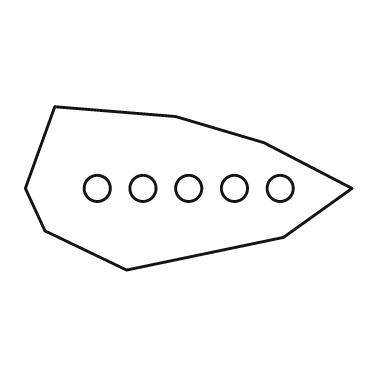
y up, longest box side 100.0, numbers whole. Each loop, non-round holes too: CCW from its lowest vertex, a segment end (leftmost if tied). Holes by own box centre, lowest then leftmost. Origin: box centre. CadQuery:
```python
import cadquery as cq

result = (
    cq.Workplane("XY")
    .moveTo(-19.0, -25.0)
    .lineTo(29.0, -15.0)
    .lineTo(50.0, 0.0)
    .lineTo(23.0, 14.0)
    .lineTo(-4.0, 22.0)
    .lineTo(-41.0, 25.0)
    .lineTo(-50.0, 0.0)
    .lineTo(-44.0, -13.0)
    .close()
    .moveTo(-28.0, 0.0)
    .circle(4.0)
    .moveTo(-14.0, 0.0)
    .circle(4.0)
    .moveTo(0.0, 0.0)
    .circle(4.0)
    .moveTo(14.0, 0.0)
    .circle(4.0)
    .moveTo(28.0, 0.0)
    .circle(4.0)
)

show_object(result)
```